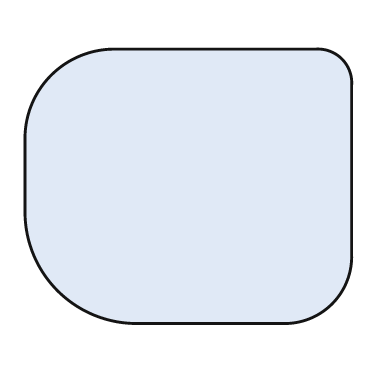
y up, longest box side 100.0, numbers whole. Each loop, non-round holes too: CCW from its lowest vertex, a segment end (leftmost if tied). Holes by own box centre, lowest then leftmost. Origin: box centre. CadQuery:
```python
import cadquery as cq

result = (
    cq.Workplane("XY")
    .moveTo(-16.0, -42.0)
    .lineTo(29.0, -42.0)
    .threePointArc((44.0, -36.0), (50.0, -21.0))
    .lineTo(50.0, 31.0)
    .threePointArc((47.0, 39.0), (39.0, 42.0))
    .lineTo(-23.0, 42.0)
    .threePointArc((-42.0, 34.0), (-50.0, 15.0))
    .lineTo(-50.0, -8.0)
    .threePointArc((-40.0, -32.0), (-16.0, -42.0))
    .close()
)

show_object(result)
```